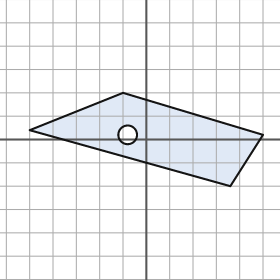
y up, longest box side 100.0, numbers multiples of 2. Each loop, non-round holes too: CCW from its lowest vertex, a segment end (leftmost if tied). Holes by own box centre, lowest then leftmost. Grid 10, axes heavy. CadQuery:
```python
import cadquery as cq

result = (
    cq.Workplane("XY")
    .moveTo(36.0, -20.0)
    .lineTo(50.0, 2.0)
    .lineTo(-10.0, 20.0)
    .lineTo(-50.0, 4.0)
    .close()
    .moveTo(-8.0, 2.0)
    .circle(4.0)
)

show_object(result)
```